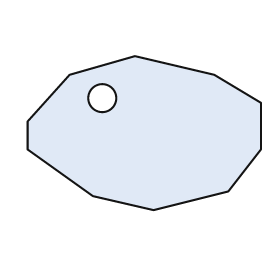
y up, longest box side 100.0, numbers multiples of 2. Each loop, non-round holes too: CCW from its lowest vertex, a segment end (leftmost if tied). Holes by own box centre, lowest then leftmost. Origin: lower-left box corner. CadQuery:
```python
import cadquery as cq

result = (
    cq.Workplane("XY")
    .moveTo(54.0, 0.0)
    .lineTo(86.0, 8.0)
    .lineTo(100.0, 26.0)
    .lineTo(100.0, 46.0)
    .lineTo(80.0, 58.0)
    .lineTo(46.0, 66.0)
    .lineTo(18.0, 58.0)
    .lineTo(0.0, 38.0)
    .lineTo(0.0, 26.0)
    .lineTo(28.0, 6.0)
    .close()
    .moveTo(32.0, 48.0)
    .circle(6.0)
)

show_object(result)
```